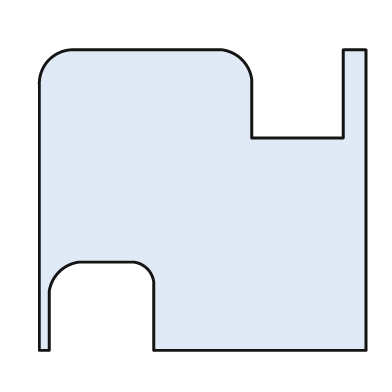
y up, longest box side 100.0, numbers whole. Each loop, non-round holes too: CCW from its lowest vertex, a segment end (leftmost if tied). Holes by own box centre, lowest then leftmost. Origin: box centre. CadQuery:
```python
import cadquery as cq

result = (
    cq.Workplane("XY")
    .moveTo(-50.0, -46.0)
    .lineTo(-47.0, -46.0)
    .lineTo(-47.0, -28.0)
    .threePointArc((-44.0, -22.0), (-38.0, -19.0))
    .lineTo(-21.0, -19.0)
    .threePointArc((-17.0, -21.0), (-15.0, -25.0))
    .lineTo(-15.0, -46.0)
    .lineTo(50.0, -46.0)
    .lineTo(50.0, 46.0)
    .lineTo(43.0, 46.0)
    .lineTo(43.0, 19.0)
    .lineTo(15.0, 19.0)
    .lineTo(15.0, 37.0)
    .threePointArc((12.0, 43.0), (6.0, 46.0))
    .lineTo(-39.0, 46.0)
    .threePointArc((-47.0, 43.0), (-50.0, 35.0))
    .close()
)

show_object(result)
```